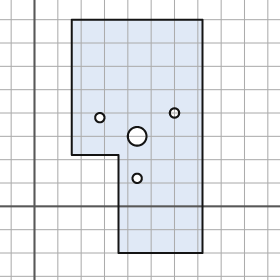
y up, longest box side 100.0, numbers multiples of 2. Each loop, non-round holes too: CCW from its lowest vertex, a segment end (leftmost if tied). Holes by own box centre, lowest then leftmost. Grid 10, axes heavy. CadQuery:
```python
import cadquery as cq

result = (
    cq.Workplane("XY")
    .moveTo(36.0, -20.0)
    .lineTo(72.0, -20.0)
    .lineTo(72.0, 80.0)
    .lineTo(16.0, 80.0)
    .lineTo(16.0, 22.0)
    .lineTo(36.0, 22.0)
    .close()
    .moveTo(44.0, 12.0)
    .circle(2.0)
    .moveTo(44.0, 30.0)
    .circle(4.0)
    .moveTo(28.0, 38.0)
    .circle(2.0)
    .moveTo(60.0, 40.0)
    .circle(2.0)
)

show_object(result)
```